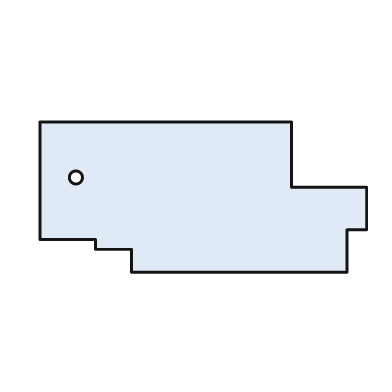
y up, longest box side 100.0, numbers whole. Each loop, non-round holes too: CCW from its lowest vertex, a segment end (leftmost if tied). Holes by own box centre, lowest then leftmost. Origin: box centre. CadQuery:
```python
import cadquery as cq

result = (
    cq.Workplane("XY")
    .moveTo(-22.0, -23.0)
    .lineTo(44.0, -23.0)
    .lineTo(44.0, -10.0)
    .lineTo(50.0, -10.0)
    .lineTo(50.0, 3.0)
    .lineTo(27.0, 3.0)
    .lineTo(27.0, 23.0)
    .lineTo(-50.0, 23.0)
    .lineTo(-50.0, -13.0)
    .lineTo(-33.0, -13.0)
    .lineTo(-33.0, -16.0)
    .lineTo(-22.0, -16.0)
    .close()
    .moveTo(-39.0, 6.0)
    .circle(2.0)
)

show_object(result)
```